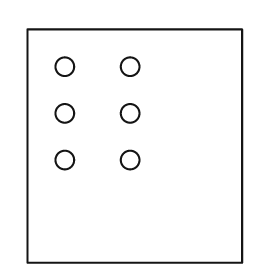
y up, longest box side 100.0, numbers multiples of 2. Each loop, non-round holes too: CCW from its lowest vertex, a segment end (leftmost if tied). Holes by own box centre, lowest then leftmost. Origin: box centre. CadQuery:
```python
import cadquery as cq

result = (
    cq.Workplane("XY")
    .moveTo(-46.0, -50.0)
    .lineTo(46.0, -50.0)
    .lineTo(46.0, 50.0)
    .lineTo(-46.0, 50.0)
    .close()
    .moveTo(-30.0, -6.0)
    .circle(4.0)
    .moveTo(-2.0, -6.0)
    .circle(4.0)
    .moveTo(-30.0, 14.0)
    .circle(4.0)
    .moveTo(-2.0, 14.0)
    .circle(4.0)
    .moveTo(-30.0, 34.0)
    .circle(4.0)
    .moveTo(-2.0, 34.0)
    .circle(4.0)
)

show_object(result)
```